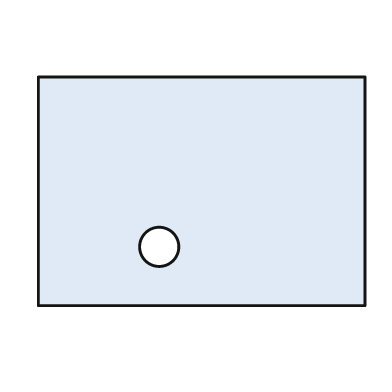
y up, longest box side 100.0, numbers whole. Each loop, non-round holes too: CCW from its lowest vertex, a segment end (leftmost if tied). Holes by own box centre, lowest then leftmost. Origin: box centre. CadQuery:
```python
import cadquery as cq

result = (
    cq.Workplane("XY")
    .moveTo(-50.0, -35.0)
    .lineTo(50.0, -35.0)
    .lineTo(50.0, 35.0)
    .lineTo(-50.0, 35.0)
    .close()
    .moveTo(-13.0, -17.0)
    .circle(6.0)
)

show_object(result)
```